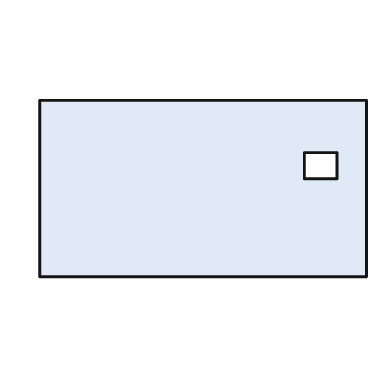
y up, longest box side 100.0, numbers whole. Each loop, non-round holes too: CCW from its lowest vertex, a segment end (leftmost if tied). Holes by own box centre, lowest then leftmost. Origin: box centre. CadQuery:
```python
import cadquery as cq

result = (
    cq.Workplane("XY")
    .moveTo(-50.0, -27.0)
    .lineTo(50.0, -27.0)
    .lineTo(50.0, 27.0)
    .lineTo(-50.0, 27.0)
    .close()
    .moveTo(31.0, 3.0)
    .lineTo(41.0, 3.0)
    .lineTo(41.0, 11.0)
    .lineTo(31.0, 11.0)
    .close()
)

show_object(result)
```